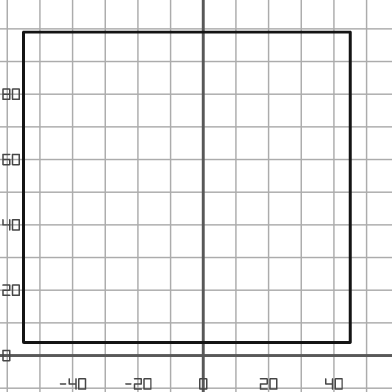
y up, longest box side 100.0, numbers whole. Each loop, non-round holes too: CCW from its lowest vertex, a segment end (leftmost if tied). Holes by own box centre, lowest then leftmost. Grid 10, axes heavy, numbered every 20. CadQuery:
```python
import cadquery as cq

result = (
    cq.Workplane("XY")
    .moveTo(-55.0, 4.0)
    .lineTo(45.0, 4.0)
    .lineTo(45.0, 99.0)
    .lineTo(-55.0, 99.0)
    .close()
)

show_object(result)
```